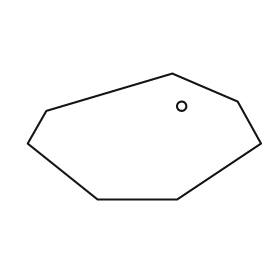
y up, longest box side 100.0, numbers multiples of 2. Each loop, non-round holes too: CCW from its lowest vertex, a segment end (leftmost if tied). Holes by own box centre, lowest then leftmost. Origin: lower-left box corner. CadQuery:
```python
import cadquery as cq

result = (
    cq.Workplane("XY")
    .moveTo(30.0, 0.0)
    .lineTo(64.0, 0.0)
    .lineTo(100.0, 24.0)
    .lineTo(90.0, 42.0)
    .lineTo(62.0, 54.0)
    .lineTo(8.0, 38.0)
    .lineTo(0.0, 24.0)
    .close()
    .moveTo(66.0, 40.0)
    .circle(2.0)
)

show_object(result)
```